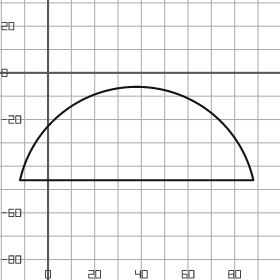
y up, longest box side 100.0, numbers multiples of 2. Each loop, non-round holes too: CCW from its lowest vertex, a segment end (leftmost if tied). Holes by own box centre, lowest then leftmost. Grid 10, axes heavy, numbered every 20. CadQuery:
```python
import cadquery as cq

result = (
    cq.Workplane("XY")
    .moveTo(-12.0, -46.0)
    .lineTo(88.0, -46.0)
    .threePointArc((38.0, -6.0), (-12.0, -46.0))
    .close()
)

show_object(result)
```